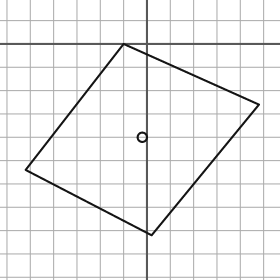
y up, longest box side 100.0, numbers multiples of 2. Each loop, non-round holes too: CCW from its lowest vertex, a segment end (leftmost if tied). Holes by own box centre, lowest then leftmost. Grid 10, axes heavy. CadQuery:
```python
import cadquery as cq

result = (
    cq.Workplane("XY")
    .moveTo(2.0, -82.0)
    .lineTo(48.0, -26.0)
    .lineTo(-10.0, 0.0)
    .lineTo(-52.0, -54.0)
    .close()
    .moveTo(-2.0, -40.0)
    .circle(2.0)
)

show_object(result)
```